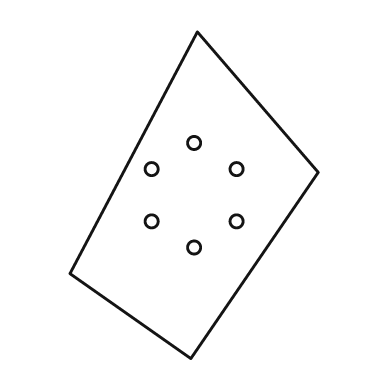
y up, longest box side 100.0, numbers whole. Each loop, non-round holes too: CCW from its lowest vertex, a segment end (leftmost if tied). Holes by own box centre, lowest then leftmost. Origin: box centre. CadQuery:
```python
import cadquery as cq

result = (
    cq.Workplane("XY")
    .moveTo(-1.0, -50.0)
    .lineTo(38.0, 7.0)
    .lineTo(1.0, 50.0)
    .lineTo(-38.0, -24.0)
    .close()
    .moveTo(0.0, -16.0)
    .circle(2.0)
    .moveTo(-13.0, -8.0)
    .circle(2.0)
    .moveTo(13.0, -8.0)
    .circle(2.0)
    .moveTo(-13.0, 8.0)
    .circle(2.0)
    .moveTo(13.0, 8.0)
    .circle(2.0)
    .moveTo(0.0, 16.0)
    .circle(2.0)
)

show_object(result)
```